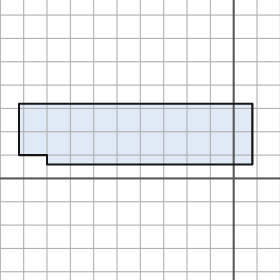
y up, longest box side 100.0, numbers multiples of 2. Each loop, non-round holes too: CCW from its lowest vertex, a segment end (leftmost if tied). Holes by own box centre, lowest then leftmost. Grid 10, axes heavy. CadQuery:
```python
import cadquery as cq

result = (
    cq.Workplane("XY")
    .moveTo(-80.0, 6.0)
    .lineTo(8.0, 6.0)
    .lineTo(8.0, 32.0)
    .lineTo(-92.0, 32.0)
    .lineTo(-92.0, 10.0)
    .lineTo(-80.0, 10.0)
    .close()
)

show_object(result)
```